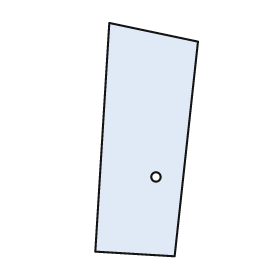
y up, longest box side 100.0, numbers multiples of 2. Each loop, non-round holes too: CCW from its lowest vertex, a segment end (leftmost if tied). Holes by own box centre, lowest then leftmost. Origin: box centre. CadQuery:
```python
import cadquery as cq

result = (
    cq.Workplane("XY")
    .moveTo(12.0, -50.0)
    .lineTo(22.0, 42.0)
    .lineTo(-16.0, 50.0)
    .lineTo(-22.0, -48.0)
    .close()
    .moveTo(4.0, -16.0)
    .circle(2.0)
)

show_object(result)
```